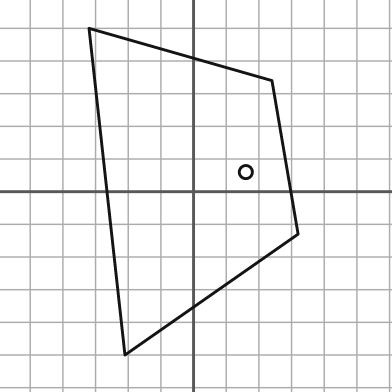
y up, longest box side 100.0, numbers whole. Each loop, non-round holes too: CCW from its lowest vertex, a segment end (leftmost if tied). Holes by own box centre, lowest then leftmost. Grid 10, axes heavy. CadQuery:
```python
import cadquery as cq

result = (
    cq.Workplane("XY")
    .moveTo(-21.0, -50.0)
    .lineTo(32.0, -13.0)
    .lineTo(24.0, 34.0)
    .lineTo(-32.0, 50.0)
    .close()
    .moveTo(16.0, 6.0)
    .circle(2.0)
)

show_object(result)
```